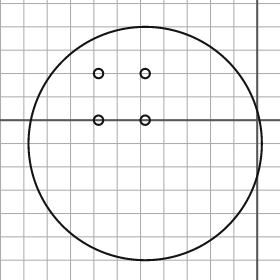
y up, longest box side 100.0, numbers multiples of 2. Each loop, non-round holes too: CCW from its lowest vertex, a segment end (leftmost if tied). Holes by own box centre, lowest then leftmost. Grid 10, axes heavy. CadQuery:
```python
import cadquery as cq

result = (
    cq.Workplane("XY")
    .moveTo(-48.0, -10.0)
    .circle(50.0)
    .moveTo(-68.0, 0.0)
    .circle(2.0)
    .moveTo(-48.0, 0.0)
    .circle(2.0)
    .moveTo(-68.0, 20.0)
    .circle(2.0)
    .moveTo(-48.0, 20.0)
    .circle(2.0)
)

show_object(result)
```